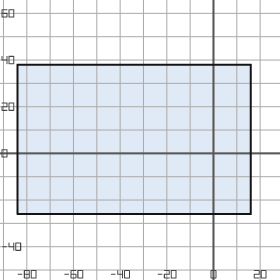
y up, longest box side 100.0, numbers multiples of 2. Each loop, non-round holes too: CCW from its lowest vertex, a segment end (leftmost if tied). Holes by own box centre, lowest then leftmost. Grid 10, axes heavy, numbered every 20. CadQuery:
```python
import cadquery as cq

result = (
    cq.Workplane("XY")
    .moveTo(-84.0, -26.0)
    .lineTo(16.0, -26.0)
    .lineTo(16.0, 38.0)
    .lineTo(-84.0, 38.0)
    .close()
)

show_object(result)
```